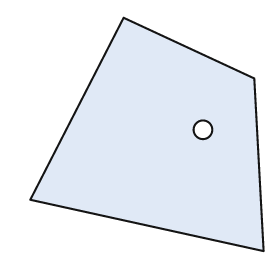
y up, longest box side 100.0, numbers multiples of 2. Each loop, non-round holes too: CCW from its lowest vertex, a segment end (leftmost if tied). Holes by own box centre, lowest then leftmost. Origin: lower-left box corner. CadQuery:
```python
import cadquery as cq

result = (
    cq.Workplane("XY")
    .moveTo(100.0, 0.0)
    .lineTo(96.0, 74.0)
    .lineTo(40.0, 100.0)
    .lineTo(0.0, 22.0)
    .close()
    .moveTo(74.0, 52.0)
    .circle(4.0)
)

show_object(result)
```